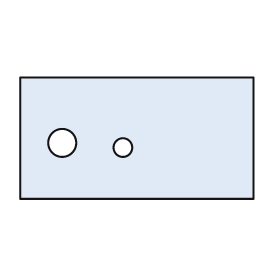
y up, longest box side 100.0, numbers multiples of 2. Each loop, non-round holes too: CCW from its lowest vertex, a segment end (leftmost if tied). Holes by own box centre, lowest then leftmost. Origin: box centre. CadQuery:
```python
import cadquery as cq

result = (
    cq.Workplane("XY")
    .moveTo(-50.0, -26.0)
    .lineTo(50.0, -26.0)
    .lineTo(50.0, 26.0)
    .lineTo(-50.0, 26.0)
    .close()
    .moveTo(-6.0, -4.0)
    .circle(4.0)
    .moveTo(-32.0, -2.0)
    .circle(6.0)
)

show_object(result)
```